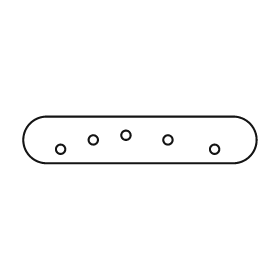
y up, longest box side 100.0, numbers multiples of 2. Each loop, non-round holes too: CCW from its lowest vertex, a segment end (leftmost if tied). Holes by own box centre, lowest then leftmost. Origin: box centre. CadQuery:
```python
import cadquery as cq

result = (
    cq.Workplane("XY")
    .moveTo(-40.0, -10.0)
    .lineTo(40.0, -10.0)
    .threePointArc((50.0, 0.0), (40.0, 10.0))
    .lineTo(-40.0, 10.0)
    .threePointArc((-50.0, 0.0), (-40.0, -10.0))
    .close()
    .moveTo(-34.0, -4.0)
    .circle(2.0)
    .moveTo(32.0, -4.0)
    .circle(2.0)
    .moveTo(-20.0, 0.0)
    .circle(2.0)
    .moveTo(12.0, 0.0)
    .circle(2.0)
    .moveTo(-6.0, 2.0)
    .circle(2.0)
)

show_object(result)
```